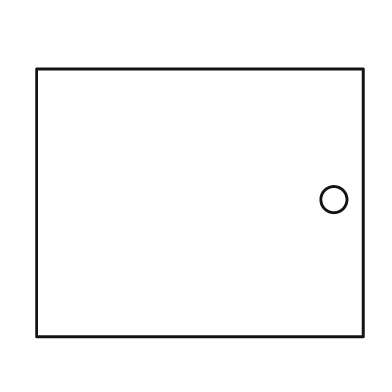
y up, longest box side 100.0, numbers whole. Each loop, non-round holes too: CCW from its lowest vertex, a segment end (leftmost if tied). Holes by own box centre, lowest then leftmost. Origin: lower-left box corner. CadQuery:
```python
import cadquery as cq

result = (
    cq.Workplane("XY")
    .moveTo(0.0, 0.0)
    .lineTo(100.0, 0.0)
    .lineTo(100.0, 82.0)
    .lineTo(0.0, 82.0)
    .close()
    .moveTo(91.0, 42.0)
    .circle(4.0)
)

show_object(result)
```